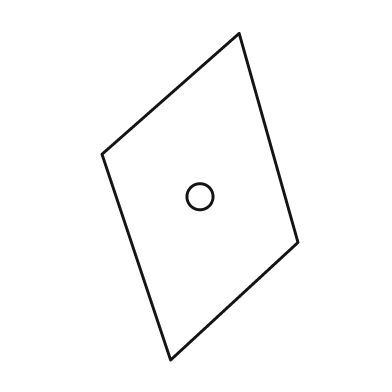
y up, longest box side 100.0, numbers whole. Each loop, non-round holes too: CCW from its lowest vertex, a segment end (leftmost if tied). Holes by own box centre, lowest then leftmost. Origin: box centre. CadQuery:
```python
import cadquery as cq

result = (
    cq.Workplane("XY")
    .moveTo(-9.0, -50.0)
    .lineTo(30.0, -14.0)
    .lineTo(12.0, 50.0)
    .lineTo(-30.0, 13.0)
    .close()
    .moveTo(0.0, 0.0)
    .circle(4.0)
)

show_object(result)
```